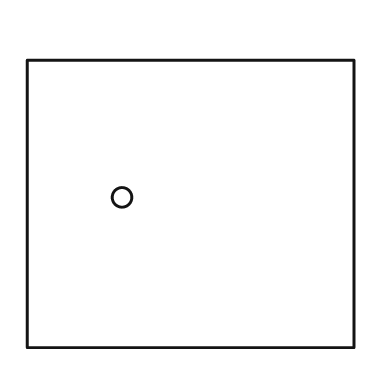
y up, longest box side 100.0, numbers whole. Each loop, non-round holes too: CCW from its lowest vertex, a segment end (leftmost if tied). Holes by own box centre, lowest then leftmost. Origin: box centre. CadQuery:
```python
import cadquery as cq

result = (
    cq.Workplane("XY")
    .moveTo(-50.0, -44.0)
    .lineTo(50.0, -44.0)
    .lineTo(50.0, 44.0)
    .lineTo(-50.0, 44.0)
    .close()
    .moveTo(-21.0, 2.0)
    .circle(3.0)
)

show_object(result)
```